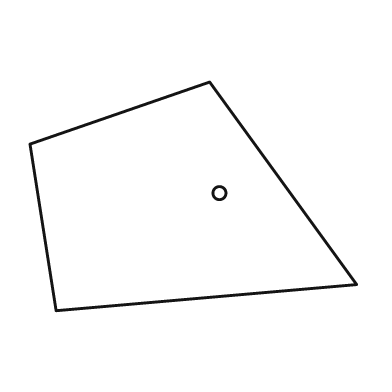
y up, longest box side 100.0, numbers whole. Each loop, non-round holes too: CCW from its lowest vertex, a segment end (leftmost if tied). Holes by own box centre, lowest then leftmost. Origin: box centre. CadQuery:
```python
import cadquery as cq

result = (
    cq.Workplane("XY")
    .moveTo(-42.0, -35.0)
    .lineTo(50.0, -27.0)
    .lineTo(5.0, 35.0)
    .lineTo(-50.0, 16.0)
    .close()
    .moveTo(8.0, 1.0)
    .circle(2.0)
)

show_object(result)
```